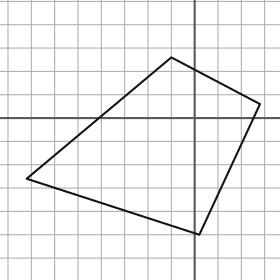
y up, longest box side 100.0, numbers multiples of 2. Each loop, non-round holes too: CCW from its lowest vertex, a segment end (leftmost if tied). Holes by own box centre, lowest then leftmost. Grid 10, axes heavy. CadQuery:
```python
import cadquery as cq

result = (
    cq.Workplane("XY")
    .moveTo(2.0, -50.0)
    .lineTo(28.0, 6.0)
    .lineTo(-10.0, 26.0)
    .lineTo(-72.0, -26.0)
    .close()
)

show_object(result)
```